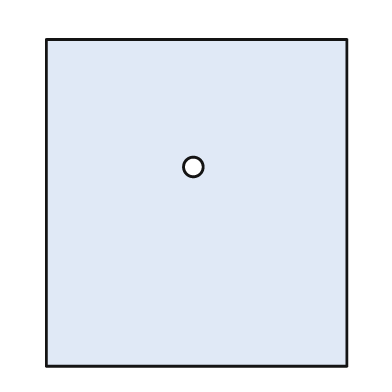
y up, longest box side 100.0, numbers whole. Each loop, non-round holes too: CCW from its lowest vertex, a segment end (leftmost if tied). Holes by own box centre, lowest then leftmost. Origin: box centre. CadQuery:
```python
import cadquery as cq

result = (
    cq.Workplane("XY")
    .moveTo(-46.0, -50.0)
    .lineTo(46.0, -50.0)
    .lineTo(46.0, 50.0)
    .lineTo(-46.0, 50.0)
    .close()
    .moveTo(-1.0, 11.0)
    .circle(3.0)
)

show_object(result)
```